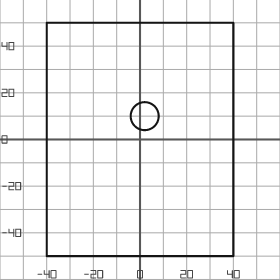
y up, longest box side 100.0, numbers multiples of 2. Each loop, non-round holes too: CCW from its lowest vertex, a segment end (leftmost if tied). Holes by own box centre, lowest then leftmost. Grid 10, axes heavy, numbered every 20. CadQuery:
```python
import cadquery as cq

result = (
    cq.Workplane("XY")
    .moveTo(-40.0, -50.0)
    .lineTo(40.0, -50.0)
    .lineTo(40.0, 50.0)
    .lineTo(-40.0, 50.0)
    .close()
    .moveTo(2.0, 10.0)
    .circle(6.0)
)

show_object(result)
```